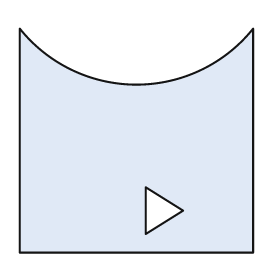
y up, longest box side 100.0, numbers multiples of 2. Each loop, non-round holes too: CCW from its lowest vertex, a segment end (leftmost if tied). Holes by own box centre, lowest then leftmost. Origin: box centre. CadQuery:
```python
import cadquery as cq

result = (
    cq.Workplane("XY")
    .moveTo(-50.0, -48.0)
    .lineTo(50.0, -48.0)
    .lineTo(50.0, 48.0)
    .threePointArc((0.0, 24.0), (-50.0, 48.0))
    .close()
    .moveTo(4.0, -40.0)
    .lineTo(20.0, -30.0)
    .lineTo(4.0, -20.0)
    .close()
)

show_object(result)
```